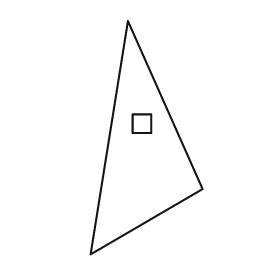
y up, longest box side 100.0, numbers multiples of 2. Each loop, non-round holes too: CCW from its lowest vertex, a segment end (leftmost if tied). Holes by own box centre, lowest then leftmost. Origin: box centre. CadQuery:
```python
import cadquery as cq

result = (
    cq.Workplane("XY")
    .moveTo(-24.0, -50.0)
    .lineTo(24.0, -22.0)
    .lineTo(-8.0, 50.0)
    .close()
    .moveTo(-6.0, 2.0)
    .lineTo(2.0, 2.0)
    .lineTo(2.0, 10.0)
    .lineTo(-6.0, 10.0)
    .close()
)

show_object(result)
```